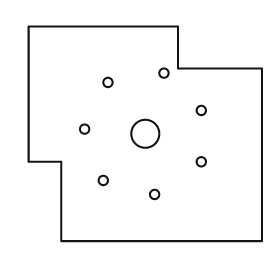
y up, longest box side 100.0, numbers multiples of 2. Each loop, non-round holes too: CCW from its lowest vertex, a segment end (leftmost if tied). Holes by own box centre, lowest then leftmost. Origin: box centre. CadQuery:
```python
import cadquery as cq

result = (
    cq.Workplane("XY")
    .moveTo(-36.0, -46.0)
    .lineTo(50.0, -46.0)
    .lineTo(50.0, 28.0)
    .lineTo(14.0, 28.0)
    .lineTo(14.0, 46.0)
    .lineTo(-50.0, 46.0)
    .lineTo(-50.0, -12.0)
    .lineTo(-36.0, -12.0)
    .close()
    .moveTo(4.0, -26.0)
    .circle(2.0)
    .moveTo(-18.0, -20.0)
    .circle(2.0)
    .moveTo(24.0, -12.0)
    .circle(2.0)
    .moveTo(0.0, 0.0)
    .circle(6.0)
    .moveTo(-26.0, 2.0)
    .circle(2.0)
    .moveTo(24.0, 10.0)
    .circle(2.0)
    .moveTo(-16.0, 22.0)
    .circle(2.0)
    .moveTo(8.0, 26.0)
    .circle(2.0)
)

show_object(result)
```